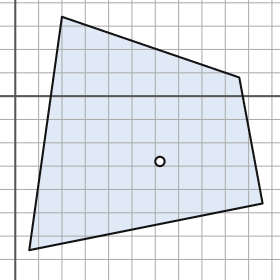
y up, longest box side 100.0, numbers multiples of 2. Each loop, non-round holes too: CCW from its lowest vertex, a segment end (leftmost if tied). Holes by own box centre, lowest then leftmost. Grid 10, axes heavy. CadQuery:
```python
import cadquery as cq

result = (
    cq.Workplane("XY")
    .moveTo(6.0, -66.0)
    .lineTo(106.0, -46.0)
    .lineTo(96.0, 8.0)
    .lineTo(20.0, 34.0)
    .close()
    .moveTo(62.0, -28.0)
    .circle(2.0)
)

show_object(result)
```